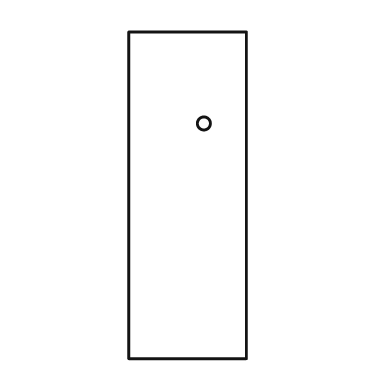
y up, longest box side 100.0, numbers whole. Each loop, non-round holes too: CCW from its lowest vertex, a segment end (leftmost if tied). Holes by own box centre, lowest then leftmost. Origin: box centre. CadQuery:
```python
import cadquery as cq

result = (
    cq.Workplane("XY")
    .moveTo(-18.0, -50.0)
    .lineTo(18.0, -50.0)
    .lineTo(18.0, 50.0)
    .lineTo(-18.0, 50.0)
    .close()
    .moveTo(5.0, 22.0)
    .circle(2.0)
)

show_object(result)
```